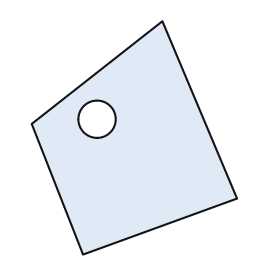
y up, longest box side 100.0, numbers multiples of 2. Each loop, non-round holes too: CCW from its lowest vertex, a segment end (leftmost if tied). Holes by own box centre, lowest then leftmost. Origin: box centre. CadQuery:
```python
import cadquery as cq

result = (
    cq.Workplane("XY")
    .moveTo(-22.0, -50.0)
    .lineTo(44.0, -26.0)
    .lineTo(12.0, 50.0)
    .lineTo(-44.0, 6.0)
    .close()
    .moveTo(-16.0, 8.0)
    .circle(8.0)
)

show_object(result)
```